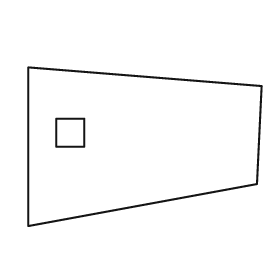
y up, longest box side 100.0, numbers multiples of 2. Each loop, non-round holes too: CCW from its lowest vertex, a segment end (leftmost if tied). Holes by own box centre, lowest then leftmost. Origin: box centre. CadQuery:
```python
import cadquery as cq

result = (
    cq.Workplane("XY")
    .moveTo(-50.0, -34.0)
    .lineTo(48.0, -16.0)
    .lineTo(50.0, 26.0)
    .lineTo(-50.0, 34.0)
    .close()
    .moveTo(-38.0, 0.0)
    .lineTo(-26.0, 0.0)
    .lineTo(-26.0, 12.0)
    .lineTo(-38.0, 12.0)
    .close()
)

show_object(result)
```